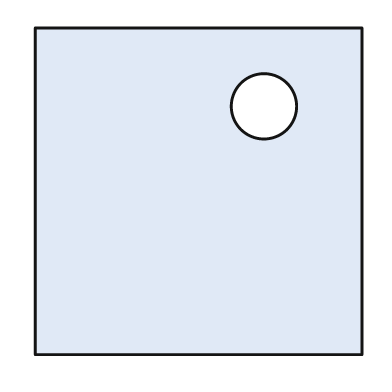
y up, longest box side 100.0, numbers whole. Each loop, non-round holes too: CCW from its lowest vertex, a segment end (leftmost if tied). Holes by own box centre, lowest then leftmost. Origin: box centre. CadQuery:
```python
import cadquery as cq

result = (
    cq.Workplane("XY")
    .moveTo(-50.0, -50.0)
    .lineTo(50.0, -50.0)
    .lineTo(50.0, 50.0)
    .lineTo(-50.0, 50.0)
    .close()
    .moveTo(20.0, 26.0)
    .circle(10.0)
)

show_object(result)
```